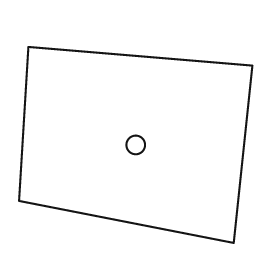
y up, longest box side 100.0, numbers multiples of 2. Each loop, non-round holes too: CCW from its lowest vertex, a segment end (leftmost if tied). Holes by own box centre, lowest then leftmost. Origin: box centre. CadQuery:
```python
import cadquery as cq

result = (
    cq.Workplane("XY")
    .moveTo(42.0, -42.0)
    .lineTo(50.0, 34.0)
    .lineTo(-46.0, 42.0)
    .lineTo(-50.0, -24.0)
    .close()
    .moveTo(0.0, 0.0)
    .circle(4.0)
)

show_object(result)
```